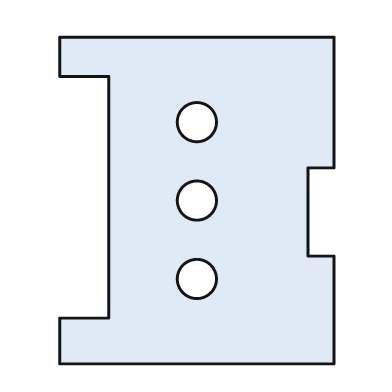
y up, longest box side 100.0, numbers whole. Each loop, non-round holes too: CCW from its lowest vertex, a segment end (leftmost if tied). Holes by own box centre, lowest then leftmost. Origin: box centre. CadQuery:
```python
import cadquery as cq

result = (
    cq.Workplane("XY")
    .moveTo(-42.0, -50.0)
    .lineTo(42.0, -50.0)
    .lineTo(42.0, -17.0)
    .lineTo(34.0, -17.0)
    .lineTo(34.0, 10.0)
    .lineTo(42.0, 10.0)
    .lineTo(42.0, 50.0)
    .lineTo(-42.0, 50.0)
    .lineTo(-42.0, 38.0)
    .lineTo(-27.0, 38.0)
    .lineTo(-27.0, -36.0)
    .lineTo(-42.0, -36.0)
    .close()
    .moveTo(0.0, -24.0)
    .circle(6.0)
    .moveTo(0.0, 0.0)
    .circle(6.0)
    .moveTo(0.0, 24.0)
    .circle(6.0)
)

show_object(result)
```